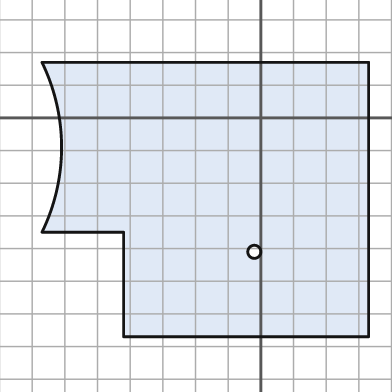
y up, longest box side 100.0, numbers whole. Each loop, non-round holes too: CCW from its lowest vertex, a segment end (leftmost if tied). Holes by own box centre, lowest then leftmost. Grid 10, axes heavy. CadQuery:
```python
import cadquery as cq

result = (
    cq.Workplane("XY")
    .moveTo(-42.0, -67.0)
    .lineTo(33.0, -67.0)
    .lineTo(33.0, 17.0)
    .lineTo(-67.0, 17.0)
    .threePointArc((-61.0, -9.0), (-67.0, -35.0))
    .lineTo(-42.0, -35.0)
    .close()
    .moveTo(-2.0, -41.0)
    .circle(2.0)
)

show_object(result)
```